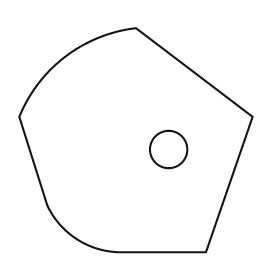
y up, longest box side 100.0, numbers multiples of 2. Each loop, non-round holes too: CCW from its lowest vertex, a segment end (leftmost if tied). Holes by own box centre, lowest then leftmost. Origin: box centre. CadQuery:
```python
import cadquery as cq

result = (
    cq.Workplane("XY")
    .moveTo(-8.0, -48.0)
    .lineTo(30.0, -48.0)
    .lineTo(50.0, 10.0)
    .lineTo(0.0, 48.0)
    .threePointArc((-30.0, 36.0), (-50.0, 10.0))
    .lineTo(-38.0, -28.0)
    .threePointArc((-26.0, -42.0), (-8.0, -48.0))
    .close()
    .moveTo(14.0, -4.0)
    .circle(8.0)
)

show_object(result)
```